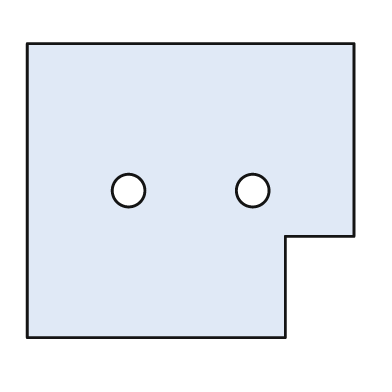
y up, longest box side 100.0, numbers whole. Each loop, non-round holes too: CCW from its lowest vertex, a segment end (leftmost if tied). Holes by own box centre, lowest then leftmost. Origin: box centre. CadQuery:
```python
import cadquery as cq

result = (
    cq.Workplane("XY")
    .moveTo(-50.0, -45.0)
    .lineTo(29.0, -45.0)
    .lineTo(29.0, -14.0)
    .lineTo(50.0, -14.0)
    .lineTo(50.0, 45.0)
    .lineTo(-50.0, 45.0)
    .close()
    .moveTo(-19.0, 0.0)
    .circle(5.0)
    .moveTo(19.0, 0.0)
    .circle(5.0)
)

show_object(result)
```